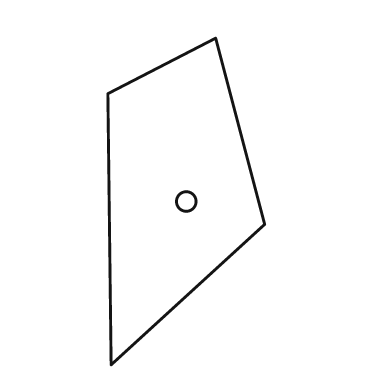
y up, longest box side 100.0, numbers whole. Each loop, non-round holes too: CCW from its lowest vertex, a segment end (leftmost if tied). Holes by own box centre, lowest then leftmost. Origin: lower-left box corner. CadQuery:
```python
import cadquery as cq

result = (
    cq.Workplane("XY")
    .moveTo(1.0, 0.0)
    .lineTo(48.0, 43.0)
    .lineTo(33.0, 100.0)
    .lineTo(0.0, 83.0)
    .close()
    .moveTo(24.0, 50.0)
    .circle(3.0)
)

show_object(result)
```